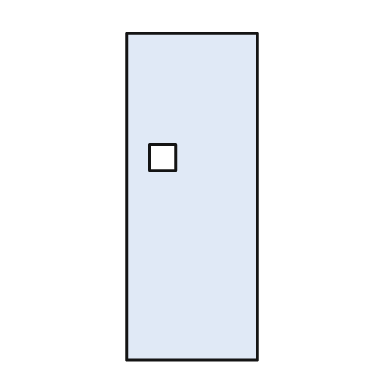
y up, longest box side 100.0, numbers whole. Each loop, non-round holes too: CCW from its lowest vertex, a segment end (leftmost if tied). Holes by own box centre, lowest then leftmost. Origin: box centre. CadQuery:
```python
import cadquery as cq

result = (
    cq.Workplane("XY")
    .moveTo(-20.0, -50.0)
    .lineTo(20.0, -50.0)
    .lineTo(20.0, 50.0)
    .lineTo(-20.0, 50.0)
    .close()
    .moveTo(-13.0, 8.0)
    .lineTo(-5.0, 8.0)
    .lineTo(-5.0, 16.0)
    .lineTo(-13.0, 16.0)
    .close()
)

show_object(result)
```